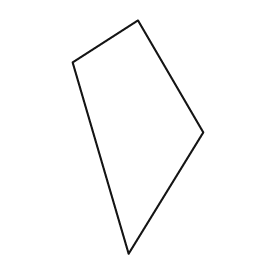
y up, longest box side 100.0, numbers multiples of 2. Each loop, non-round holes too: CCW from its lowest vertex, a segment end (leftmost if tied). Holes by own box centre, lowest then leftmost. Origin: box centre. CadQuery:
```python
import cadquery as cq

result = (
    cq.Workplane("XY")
    .moveTo(-4.0, -50.0)
    .lineTo(28.0, 2.0)
    .lineTo(0.0, 50.0)
    .lineTo(-28.0, 32.0)
    .close()
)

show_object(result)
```